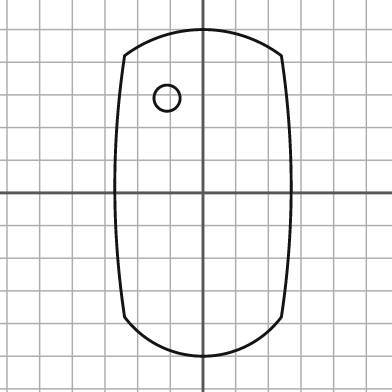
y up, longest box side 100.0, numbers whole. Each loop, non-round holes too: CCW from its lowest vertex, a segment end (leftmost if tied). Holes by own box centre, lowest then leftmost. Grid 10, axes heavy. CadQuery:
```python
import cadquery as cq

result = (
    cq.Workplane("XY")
    .moveTo(-24.0, -38.0)
    .threePointArc((0.0, -50.0), (24.0, -38.0))
    .threePointArc((27.0, 2.0), (24.0, 42.0))
    .threePointArc((0.0, 50.0), (-24.0, 42.0))
    .threePointArc((-27.0, 2.0), (-24.0, -38.0))
    .close()
    .moveTo(-11.0, 29.0)
    .circle(4.0)
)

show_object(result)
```